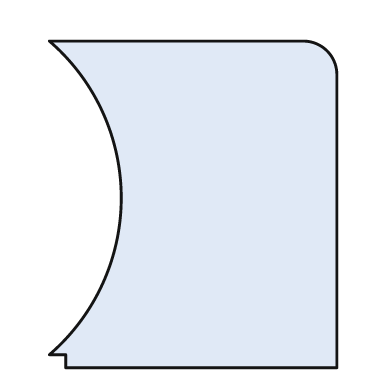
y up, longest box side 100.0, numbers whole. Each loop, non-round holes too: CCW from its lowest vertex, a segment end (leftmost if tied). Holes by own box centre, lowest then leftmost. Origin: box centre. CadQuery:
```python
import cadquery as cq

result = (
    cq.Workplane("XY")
    .moveTo(-39.0, -50.0)
    .lineTo(44.0, -50.0)
    .lineTo(44.0, 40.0)
    .threePointArc((41.0, 47.0), (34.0, 50.0))
    .lineTo(-44.0, 50.0)
    .threePointArc((-22.0, 2.0), (-44.0, -46.0))
    .lineTo(-39.0, -46.0)
    .close()
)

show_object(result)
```